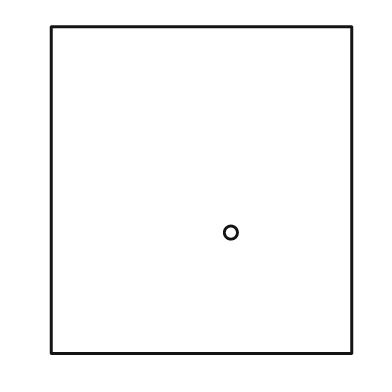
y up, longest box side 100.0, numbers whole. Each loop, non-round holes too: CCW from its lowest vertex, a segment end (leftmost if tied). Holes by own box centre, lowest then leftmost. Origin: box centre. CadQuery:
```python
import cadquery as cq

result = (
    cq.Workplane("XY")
    .moveTo(-46.0, -50.0)
    .lineTo(46.0, -50.0)
    .lineTo(46.0, 50.0)
    .lineTo(-46.0, 50.0)
    .close()
    .moveTo(9.0, -13.0)
    .circle(2.0)
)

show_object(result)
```